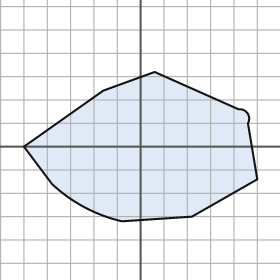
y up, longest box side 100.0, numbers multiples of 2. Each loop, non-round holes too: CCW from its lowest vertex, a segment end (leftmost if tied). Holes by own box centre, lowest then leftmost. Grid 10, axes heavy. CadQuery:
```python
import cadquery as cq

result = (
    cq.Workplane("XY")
    .moveTo(-8.0, -32.0)
    .lineTo(22.0, -30.0)
    .lineTo(50.0, -14.0)
    .lineTo(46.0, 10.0)
    .threePointArc((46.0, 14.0), (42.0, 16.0))
    .lineTo(6.0, 32.0)
    .lineTo(-16.0, 24.0)
    .lineTo(-50.0, 0.0)
    .lineTo(-38.0, -16.0)
    .threePointArc((-24.0, -26.0), (-8.0, -32.0))
    .close()
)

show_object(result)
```